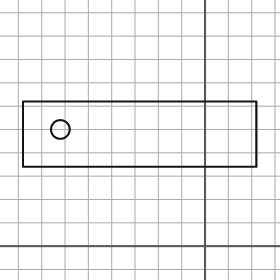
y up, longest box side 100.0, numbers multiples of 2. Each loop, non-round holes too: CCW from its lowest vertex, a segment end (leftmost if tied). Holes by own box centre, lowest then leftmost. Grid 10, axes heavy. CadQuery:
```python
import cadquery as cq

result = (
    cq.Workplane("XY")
    .moveTo(-78.0, 34.0)
    .lineTo(22.0, 34.0)
    .lineTo(22.0, 62.0)
    .lineTo(-78.0, 62.0)
    .close()
    .moveTo(-62.0, 50.0)
    .circle(4.0)
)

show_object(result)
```